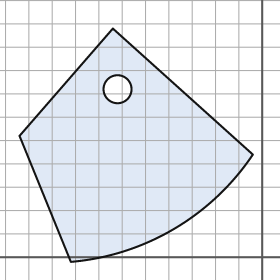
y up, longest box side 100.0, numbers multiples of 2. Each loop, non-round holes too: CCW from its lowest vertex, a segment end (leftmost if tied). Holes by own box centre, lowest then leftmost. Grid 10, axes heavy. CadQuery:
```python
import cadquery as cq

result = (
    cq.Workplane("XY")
    .moveTo(-82.0, -2.0)
    .threePointArc((-38.0, 12.0), (-4.0, 44.0))
    .lineTo(-64.0, 98.0)
    .lineTo(-104.0, 52.0)
    .close()
    .moveTo(-62.0, 72.0)
    .circle(6.0)
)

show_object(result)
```